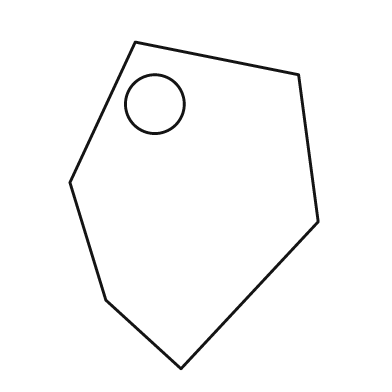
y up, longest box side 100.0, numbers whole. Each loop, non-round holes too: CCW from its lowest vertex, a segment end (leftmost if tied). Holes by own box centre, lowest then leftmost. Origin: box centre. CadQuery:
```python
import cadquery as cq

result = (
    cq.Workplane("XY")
    .moveTo(-4.0, -50.0)
    .lineTo(38.0, -5.0)
    .lineTo(32.0, 40.0)
    .lineTo(-18.0, 50.0)
    .lineTo(-38.0, 7.0)
    .lineTo(-27.0, -29.0)
    .close()
    .moveTo(-12.0, 31.0)
    .circle(9.0)
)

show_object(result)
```